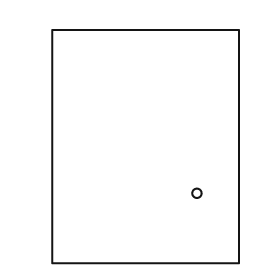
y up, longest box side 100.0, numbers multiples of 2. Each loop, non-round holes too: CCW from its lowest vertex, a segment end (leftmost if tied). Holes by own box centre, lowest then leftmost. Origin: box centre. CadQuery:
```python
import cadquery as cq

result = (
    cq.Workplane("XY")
    .moveTo(-40.0, -50.0)
    .lineTo(40.0, -50.0)
    .lineTo(40.0, 50.0)
    .lineTo(-40.0, 50.0)
    .close()
    .moveTo(22.0, -20.0)
    .circle(2.0)
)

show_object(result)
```